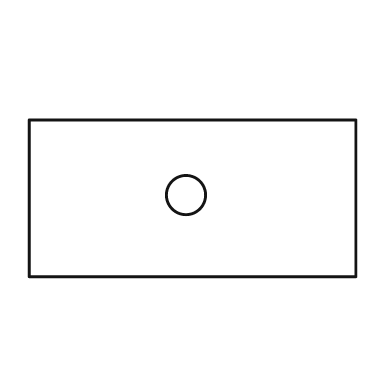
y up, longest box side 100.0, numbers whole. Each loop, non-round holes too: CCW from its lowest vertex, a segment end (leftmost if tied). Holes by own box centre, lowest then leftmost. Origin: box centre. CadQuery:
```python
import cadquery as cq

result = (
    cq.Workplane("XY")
    .moveTo(-50.0, -24.0)
    .lineTo(50.0, -24.0)
    .lineTo(50.0, 24.0)
    .lineTo(-50.0, 24.0)
    .close()
    .moveTo(-2.0, 1.0)
    .circle(6.0)
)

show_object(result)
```